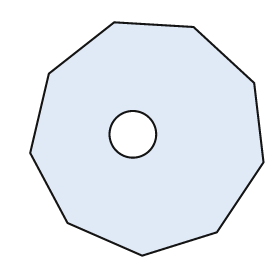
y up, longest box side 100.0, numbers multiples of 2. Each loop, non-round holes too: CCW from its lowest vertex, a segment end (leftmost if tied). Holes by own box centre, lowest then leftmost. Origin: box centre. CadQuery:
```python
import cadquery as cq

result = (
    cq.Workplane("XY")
    .moveTo(-2.0, -50.0)
    .lineTo(30.0, -40.0)
    .lineTo(50.0, -10.0)
    .lineTo(46.0, 24.0)
    .lineTo(20.0, 48.0)
    .lineTo(-14.0, 50.0)
    .lineTo(-42.0, 28.0)
    .lineTo(-50.0, -6.0)
    .lineTo(-34.0, -36.0)
    .close()
    .moveTo(-6.0, 2.0)
    .circle(10.0)
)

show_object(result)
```